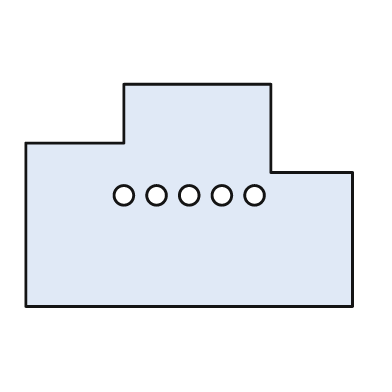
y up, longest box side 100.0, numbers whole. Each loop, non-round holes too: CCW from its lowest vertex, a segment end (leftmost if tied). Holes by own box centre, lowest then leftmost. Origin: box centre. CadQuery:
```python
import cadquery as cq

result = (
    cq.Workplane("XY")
    .moveTo(-50.0, -34.0)
    .lineTo(50.0, -34.0)
    .lineTo(50.0, 7.0)
    .lineTo(25.0, 7.0)
    .lineTo(25.0, 34.0)
    .lineTo(-20.0, 34.0)
    .lineTo(-20.0, 16.0)
    .lineTo(-50.0, 16.0)
    .close()
    .moveTo(-20.0, 0.0)
    .circle(3.0)
    .moveTo(-10.0, 0.0)
    .circle(3.0)
    .moveTo(0.0, 0.0)
    .circle(3.0)
    .moveTo(10.0, 0.0)
    .circle(3.0)
    .moveTo(20.0, 0.0)
    .circle(3.0)
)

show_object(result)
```